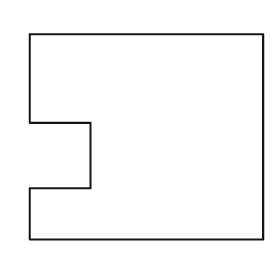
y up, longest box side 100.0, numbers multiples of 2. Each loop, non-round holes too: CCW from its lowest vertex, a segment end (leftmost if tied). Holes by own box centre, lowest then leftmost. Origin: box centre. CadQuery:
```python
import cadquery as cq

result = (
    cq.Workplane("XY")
    .moveTo(-50.0, -44.0)
    .lineTo(50.0, -44.0)
    .lineTo(50.0, 44.0)
    .lineTo(-50.0, 44.0)
    .lineTo(-50.0, 6.0)
    .lineTo(-24.0, 6.0)
    .lineTo(-24.0, -22.0)
    .lineTo(-50.0, -22.0)
    .close()
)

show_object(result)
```